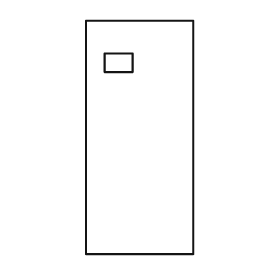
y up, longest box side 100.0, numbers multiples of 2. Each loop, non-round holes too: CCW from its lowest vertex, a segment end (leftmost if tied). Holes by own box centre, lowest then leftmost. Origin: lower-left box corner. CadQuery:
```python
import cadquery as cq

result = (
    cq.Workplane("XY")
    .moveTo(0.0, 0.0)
    .lineTo(46.0, 0.0)
    .lineTo(46.0, 100.0)
    .lineTo(0.0, 100.0)
    .close()
    .moveTo(8.0, 78.0)
    .lineTo(20.0, 78.0)
    .lineTo(20.0, 86.0)
    .lineTo(8.0, 86.0)
    .close()
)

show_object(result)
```